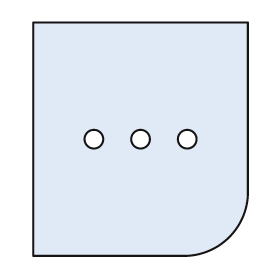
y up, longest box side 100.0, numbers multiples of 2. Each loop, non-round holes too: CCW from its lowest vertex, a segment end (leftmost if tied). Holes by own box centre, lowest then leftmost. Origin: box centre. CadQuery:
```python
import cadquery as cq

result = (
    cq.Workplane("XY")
    .moveTo(-46.0, -50.0)
    .lineTo(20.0, -50.0)
    .threePointArc((38.0, -42.0), (46.0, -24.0))
    .lineTo(46.0, 50.0)
    .lineTo(-46.0, 50.0)
    .close()
    .moveTo(-20.0, 0.0)
    .circle(4.0)
    .moveTo(0.0, 0.0)
    .circle(4.0)
    .moveTo(20.0, 0.0)
    .circle(4.0)
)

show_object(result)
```